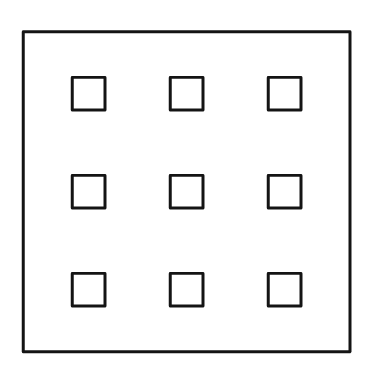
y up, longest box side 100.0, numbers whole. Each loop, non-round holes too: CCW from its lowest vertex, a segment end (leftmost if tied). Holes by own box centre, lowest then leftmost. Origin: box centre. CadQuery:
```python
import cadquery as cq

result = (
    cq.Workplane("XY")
    .moveTo(-50.0, -49.0)
    .lineTo(50.0, -49.0)
    .lineTo(50.0, 49.0)
    .lineTo(-50.0, 49.0)
    .close()
    .moveTo(-35.0, -35.0)
    .lineTo(-25.0, -35.0)
    .lineTo(-25.0, -25.0)
    .lineTo(-35.0, -25.0)
    .close()
    .moveTo(-5.0, -35.0)
    .lineTo(5.0, -35.0)
    .lineTo(5.0, -25.0)
    .lineTo(-5.0, -25.0)
    .close()
    .moveTo(25.0, -35.0)
    .lineTo(35.0, -35.0)
    .lineTo(35.0, -25.0)
    .lineTo(25.0, -25.0)
    .close()
    .moveTo(-35.0, -5.0)
    .lineTo(-25.0, -5.0)
    .lineTo(-25.0, 5.0)
    .lineTo(-35.0, 5.0)
    .close()
    .moveTo(-5.0, -5.0)
    .lineTo(5.0, -5.0)
    .lineTo(5.0, 5.0)
    .lineTo(-5.0, 5.0)
    .close()
    .moveTo(25.0, -5.0)
    .lineTo(35.0, -5.0)
    .lineTo(35.0, 5.0)
    .lineTo(25.0, 5.0)
    .close()
    .moveTo(-35.0, 25.0)
    .lineTo(-25.0, 25.0)
    .lineTo(-25.0, 35.0)
    .lineTo(-35.0, 35.0)
    .close()
    .moveTo(-5.0, 25.0)
    .lineTo(5.0, 25.0)
    .lineTo(5.0, 35.0)
    .lineTo(-5.0, 35.0)
    .close()
    .moveTo(25.0, 25.0)
    .lineTo(35.0, 25.0)
    .lineTo(35.0, 35.0)
    .lineTo(25.0, 35.0)
    .close()
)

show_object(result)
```